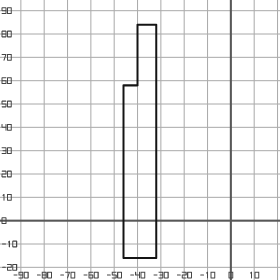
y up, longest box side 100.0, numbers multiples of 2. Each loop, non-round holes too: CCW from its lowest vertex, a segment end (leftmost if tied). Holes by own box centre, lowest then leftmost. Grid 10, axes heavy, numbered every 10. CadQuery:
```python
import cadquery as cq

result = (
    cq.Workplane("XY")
    .moveTo(-46.0, -16.0)
    .lineTo(-32.0, -16.0)
    .lineTo(-32.0, 84.0)
    .lineTo(-40.0, 84.0)
    .lineTo(-40.0, 58.0)
    .lineTo(-46.0, 58.0)
    .close()
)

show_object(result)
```